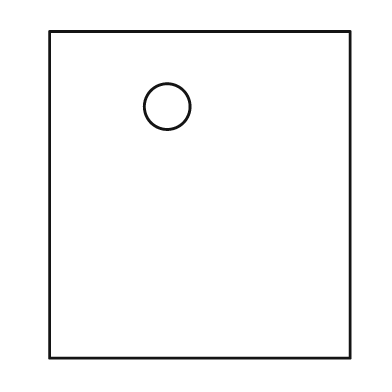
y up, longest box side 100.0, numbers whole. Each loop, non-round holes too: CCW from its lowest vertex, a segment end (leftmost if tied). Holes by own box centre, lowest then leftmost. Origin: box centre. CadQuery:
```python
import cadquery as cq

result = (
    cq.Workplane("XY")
    .moveTo(-46.0, -50.0)
    .lineTo(46.0, -50.0)
    .lineTo(46.0, 50.0)
    .lineTo(-46.0, 50.0)
    .close()
    .moveTo(-10.0, 27.0)
    .circle(7.0)
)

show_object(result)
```